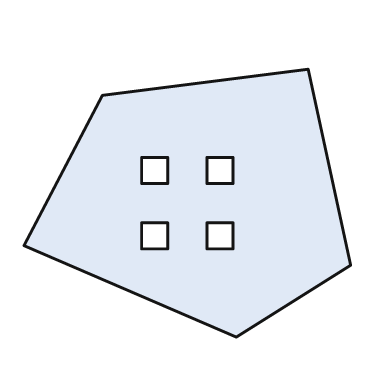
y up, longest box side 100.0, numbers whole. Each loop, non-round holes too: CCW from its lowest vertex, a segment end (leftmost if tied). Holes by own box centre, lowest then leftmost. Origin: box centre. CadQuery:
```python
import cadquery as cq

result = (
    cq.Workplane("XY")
    .moveTo(15.0, -41.0)
    .lineTo(50.0, -19.0)
    .lineTo(37.0, 41.0)
    .lineTo(-26.0, 33.0)
    .lineTo(-50.0, -13.0)
    .close()
    .moveTo(-14.0, -14.0)
    .lineTo(-6.0, -14.0)
    .lineTo(-6.0, -6.0)
    .lineTo(-14.0, -6.0)
    .close()
    .moveTo(6.0, -14.0)
    .lineTo(14.0, -14.0)
    .lineTo(14.0, -6.0)
    .lineTo(6.0, -6.0)
    .close()
    .moveTo(-14.0, 6.0)
    .lineTo(-6.0, 6.0)
    .lineTo(-6.0, 14.0)
    .lineTo(-14.0, 14.0)
    .close()
    .moveTo(6.0, 6.0)
    .lineTo(14.0, 6.0)
    .lineTo(14.0, 14.0)
    .lineTo(6.0, 14.0)
    .close()
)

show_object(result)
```